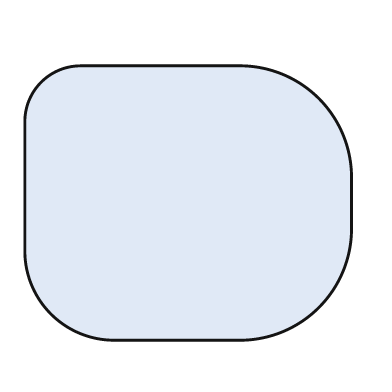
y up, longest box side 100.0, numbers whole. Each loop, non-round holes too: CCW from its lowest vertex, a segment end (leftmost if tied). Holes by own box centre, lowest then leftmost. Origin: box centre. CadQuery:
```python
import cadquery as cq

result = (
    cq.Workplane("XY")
    .moveTo(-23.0, -42.0)
    .lineTo(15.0, -42.0)
    .threePointArc((40.0, -32.0), (50.0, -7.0))
    .lineTo(50.0, 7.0)
    .threePointArc((40.0, 32.0), (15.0, 42.0))
    .lineTo(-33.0, 42.0)
    .threePointArc((-45.0, 37.0), (-50.0, 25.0))
    .lineTo(-50.0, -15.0)
    .threePointArc((-42.0, -34.0), (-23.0, -42.0))
    .close()
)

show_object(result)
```